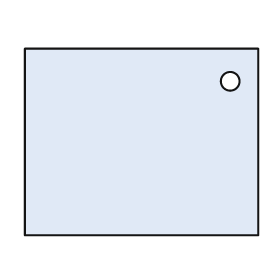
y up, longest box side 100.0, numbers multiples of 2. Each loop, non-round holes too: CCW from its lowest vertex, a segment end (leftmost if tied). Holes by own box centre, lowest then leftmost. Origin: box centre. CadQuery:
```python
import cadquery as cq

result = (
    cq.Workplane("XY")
    .moveTo(-50.0, -40.0)
    .lineTo(50.0, -40.0)
    .lineTo(50.0, 40.0)
    .lineTo(-50.0, 40.0)
    .close()
    .moveTo(38.0, 26.0)
    .circle(4.0)
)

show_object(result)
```